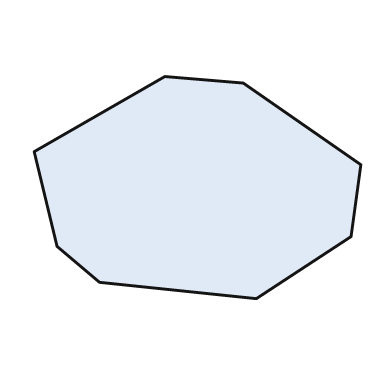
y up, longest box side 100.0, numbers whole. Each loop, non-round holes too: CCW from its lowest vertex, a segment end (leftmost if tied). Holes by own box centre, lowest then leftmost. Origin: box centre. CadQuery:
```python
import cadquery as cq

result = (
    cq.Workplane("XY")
    .moveTo(18.0, -34.0)
    .lineTo(47.0, -15.0)
    .lineTo(50.0, 7.0)
    .lineTo(14.0, 32.0)
    .lineTo(-10.0, 34.0)
    .lineTo(-50.0, 11.0)
    .lineTo(-43.0, -18.0)
    .lineTo(-30.0, -29.0)
    .close()
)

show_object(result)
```